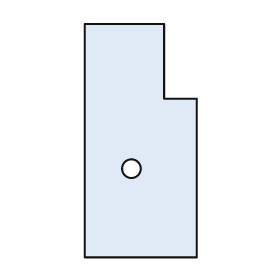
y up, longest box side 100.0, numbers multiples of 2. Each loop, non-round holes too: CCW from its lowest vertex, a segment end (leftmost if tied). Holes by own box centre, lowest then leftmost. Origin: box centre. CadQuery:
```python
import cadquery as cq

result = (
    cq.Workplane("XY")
    .moveTo(-24.0, -50.0)
    .lineTo(24.0, -50.0)
    .lineTo(24.0, 18.0)
    .lineTo(10.0, 18.0)
    .lineTo(10.0, 50.0)
    .lineTo(-24.0, 50.0)
    .close()
    .moveTo(-4.0, -12.0)
    .circle(4.0)
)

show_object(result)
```